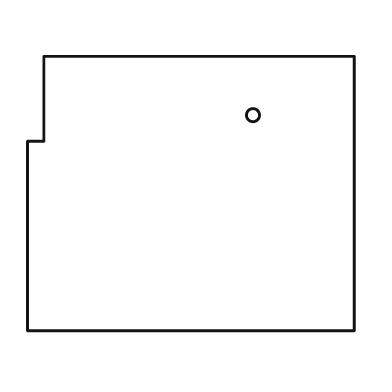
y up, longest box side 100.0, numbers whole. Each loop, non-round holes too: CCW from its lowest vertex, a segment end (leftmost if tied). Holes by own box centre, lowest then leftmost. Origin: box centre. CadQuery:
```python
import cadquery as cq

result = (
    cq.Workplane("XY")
    .moveTo(-50.0, -42.0)
    .lineTo(50.0, -42.0)
    .lineTo(50.0, 42.0)
    .lineTo(-45.0, 42.0)
    .lineTo(-45.0, 16.0)
    .lineTo(-50.0, 16.0)
    .close()
    .moveTo(19.0, 24.0)
    .circle(2.0)
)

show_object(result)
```